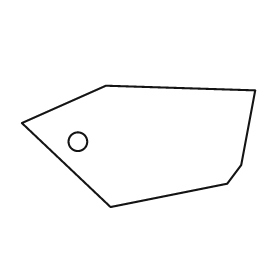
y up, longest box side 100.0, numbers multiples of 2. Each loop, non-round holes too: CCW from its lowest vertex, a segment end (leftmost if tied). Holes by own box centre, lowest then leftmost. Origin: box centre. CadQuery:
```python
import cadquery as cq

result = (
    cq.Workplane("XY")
    .moveTo(-12.0, -26.0)
    .lineTo(38.0, -16.0)
    .lineTo(44.0, -8.0)
    .lineTo(50.0, 24.0)
    .lineTo(-14.0, 26.0)
    .lineTo(-50.0, 10.0)
    .close()
    .moveTo(-26.0, 2.0)
    .circle(4.0)
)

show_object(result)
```